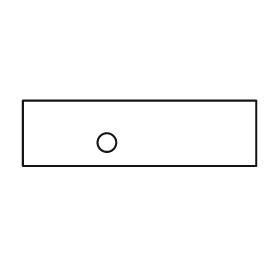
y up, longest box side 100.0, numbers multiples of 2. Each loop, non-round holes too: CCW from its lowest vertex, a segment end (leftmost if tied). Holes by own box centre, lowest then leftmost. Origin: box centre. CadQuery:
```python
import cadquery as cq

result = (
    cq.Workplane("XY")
    .moveTo(-50.0, -14.0)
    .lineTo(50.0, -14.0)
    .lineTo(50.0, 14.0)
    .lineTo(-50.0, 14.0)
    .close()
    .moveTo(-14.0, -4.0)
    .circle(4.0)
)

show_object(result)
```